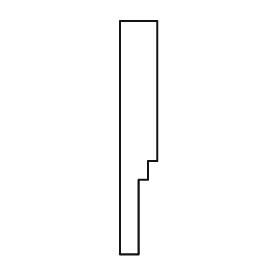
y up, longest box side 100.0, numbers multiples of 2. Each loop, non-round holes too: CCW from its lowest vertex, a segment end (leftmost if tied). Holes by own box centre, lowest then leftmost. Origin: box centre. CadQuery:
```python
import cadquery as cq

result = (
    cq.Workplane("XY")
    .moveTo(-8.0, -50.0)
    .lineTo(0.0, -50.0)
    .lineTo(0.0, -18.0)
    .lineTo(4.0, -18.0)
    .lineTo(4.0, -10.0)
    .lineTo(8.0, -10.0)
    .lineTo(8.0, 50.0)
    .lineTo(-8.0, 50.0)
    .close()
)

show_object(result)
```